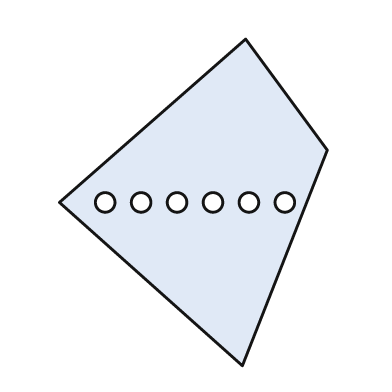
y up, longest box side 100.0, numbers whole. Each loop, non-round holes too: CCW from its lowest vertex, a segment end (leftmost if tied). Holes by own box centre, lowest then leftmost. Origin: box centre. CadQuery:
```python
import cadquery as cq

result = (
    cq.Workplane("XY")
    .moveTo(15.0, -50.0)
    .lineTo(41.0, 16.0)
    .lineTo(16.0, 50.0)
    .lineTo(-41.0, 0.0)
    .close()
    .moveTo(-27.0, 0.0)
    .circle(3.0)
    .moveTo(-16.0, 0.0)
    .circle(3.0)
    .moveTo(-5.0, 0.0)
    .circle(3.0)
    .moveTo(6.0, 0.0)
    .circle(3.0)
    .moveTo(17.0, 0.0)
    .circle(3.0)
    .moveTo(28.0, 0.0)
    .circle(3.0)
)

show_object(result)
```